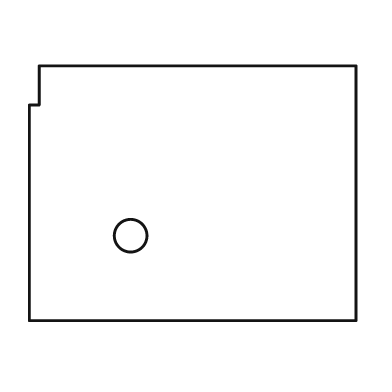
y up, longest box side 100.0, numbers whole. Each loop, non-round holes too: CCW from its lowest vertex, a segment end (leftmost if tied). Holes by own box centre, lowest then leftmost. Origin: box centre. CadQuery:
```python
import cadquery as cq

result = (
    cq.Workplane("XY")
    .moveTo(-50.0, -39.0)
    .lineTo(50.0, -39.0)
    .lineTo(50.0, 39.0)
    .lineTo(-47.0, 39.0)
    .lineTo(-47.0, 27.0)
    .lineTo(-50.0, 27.0)
    .close()
    .moveTo(-19.0, -13.0)
    .circle(5.0)
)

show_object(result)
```